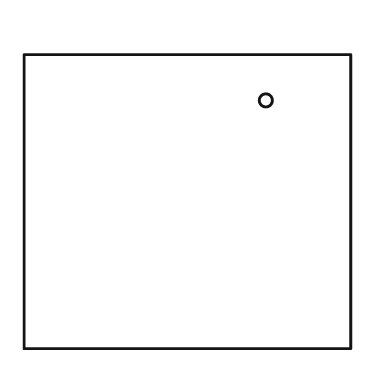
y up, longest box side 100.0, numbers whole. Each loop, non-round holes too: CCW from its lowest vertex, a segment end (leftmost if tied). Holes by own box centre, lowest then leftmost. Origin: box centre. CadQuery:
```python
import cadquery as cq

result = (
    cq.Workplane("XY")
    .moveTo(-50.0, -45.0)
    .lineTo(50.0, -45.0)
    .lineTo(50.0, 45.0)
    .lineTo(-50.0, 45.0)
    .close()
    .moveTo(24.0, 31.0)
    .circle(2.0)
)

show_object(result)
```